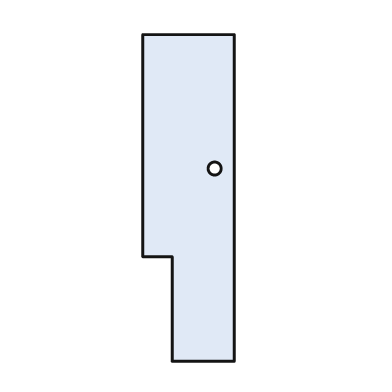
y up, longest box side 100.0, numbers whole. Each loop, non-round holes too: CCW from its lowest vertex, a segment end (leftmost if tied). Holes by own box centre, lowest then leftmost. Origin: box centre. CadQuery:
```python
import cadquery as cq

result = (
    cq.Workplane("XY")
    .moveTo(-5.0, -50.0)
    .lineTo(14.0, -50.0)
    .lineTo(14.0, 50.0)
    .lineTo(-14.0, 50.0)
    .lineTo(-14.0, -18.0)
    .lineTo(-5.0, -18.0)
    .close()
    .moveTo(8.0, 9.0)
    .circle(2.0)
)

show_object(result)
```